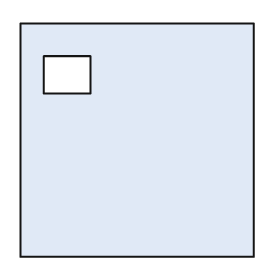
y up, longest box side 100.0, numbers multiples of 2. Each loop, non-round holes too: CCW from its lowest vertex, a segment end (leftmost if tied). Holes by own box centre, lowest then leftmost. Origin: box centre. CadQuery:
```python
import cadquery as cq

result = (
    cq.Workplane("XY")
    .moveTo(-50.0, -50.0)
    .lineTo(50.0, -50.0)
    .lineTo(50.0, 50.0)
    .lineTo(-50.0, 50.0)
    .close()
    .moveTo(-40.0, 20.0)
    .lineTo(-20.0, 20.0)
    .lineTo(-20.0, 36.0)
    .lineTo(-40.0, 36.0)
    .close()
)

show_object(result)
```